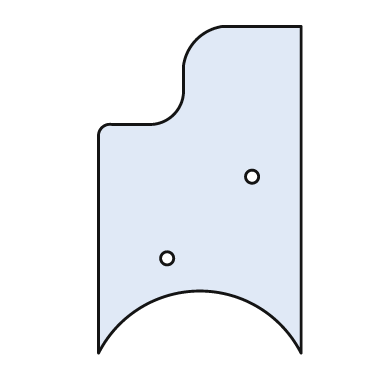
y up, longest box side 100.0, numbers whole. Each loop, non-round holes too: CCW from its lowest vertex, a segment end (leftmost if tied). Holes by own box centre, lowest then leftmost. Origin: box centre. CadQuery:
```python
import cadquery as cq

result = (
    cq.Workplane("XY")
    .moveTo(-31.0, -50.0)
    .threePointArc((0.0, -31.0), (31.0, -50.0))
    .lineTo(31.0, 50.0)
    .lineTo(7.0, 50.0)
    .threePointArc((-1.0, 46.0), (-5.0, 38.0))
    .lineTo(-5.0, 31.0)
    .threePointArc((-8.0, 23.0), (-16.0, 20.0))
    .lineTo(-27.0, 20.0)
    .threePointArc((-30.0, 19.0), (-31.0, 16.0))
    .close()
    .moveTo(-10.0, -21.0)
    .circle(2.0)
    .moveTo(16.0, 4.0)
    .circle(2.0)
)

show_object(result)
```